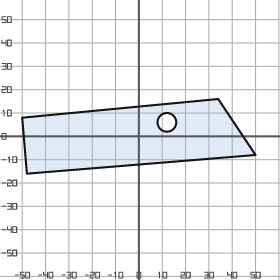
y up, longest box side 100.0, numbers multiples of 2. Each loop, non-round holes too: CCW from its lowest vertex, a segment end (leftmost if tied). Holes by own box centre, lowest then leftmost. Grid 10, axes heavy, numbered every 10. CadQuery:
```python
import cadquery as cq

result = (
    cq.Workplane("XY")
    .moveTo(-48.0, -16.0)
    .lineTo(50.0, -8.0)
    .lineTo(34.0, 16.0)
    .lineTo(-50.0, 8.0)
    .close()
    .moveTo(12.0, 6.0)
    .circle(4.0)
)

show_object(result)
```